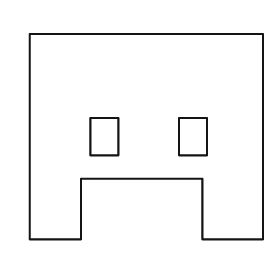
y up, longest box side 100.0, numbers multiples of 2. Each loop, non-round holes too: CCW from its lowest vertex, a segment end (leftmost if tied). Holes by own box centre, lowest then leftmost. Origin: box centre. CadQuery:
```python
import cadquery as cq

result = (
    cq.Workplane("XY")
    .moveTo(-50.0, -44.0)
    .lineTo(-28.0, -44.0)
    .lineTo(-28.0, -18.0)
    .lineTo(24.0, -18.0)
    .lineTo(24.0, -44.0)
    .lineTo(50.0, -44.0)
    .lineTo(50.0, 44.0)
    .lineTo(-50.0, 44.0)
    .close()
    .moveTo(-24.0, -8.0)
    .lineTo(-12.0, -8.0)
    .lineTo(-12.0, 8.0)
    .lineTo(-24.0, 8.0)
    .close()
    .moveTo(14.0, -8.0)
    .lineTo(26.0, -8.0)
    .lineTo(26.0, 8.0)
    .lineTo(14.0, 8.0)
    .close()
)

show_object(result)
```